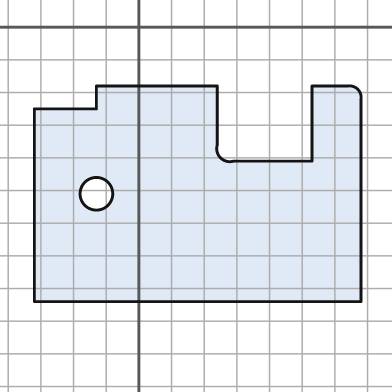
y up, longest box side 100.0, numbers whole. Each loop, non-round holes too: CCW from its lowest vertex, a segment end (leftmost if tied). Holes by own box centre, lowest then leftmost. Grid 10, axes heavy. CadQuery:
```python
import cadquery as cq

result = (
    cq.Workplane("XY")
    .moveTo(-32.0, -84.0)
    .lineTo(68.0, -84.0)
    .lineTo(68.0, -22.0)
    .threePointArc((67.0, -19.0), (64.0, -18.0))
    .lineTo(53.0, -18.0)
    .lineTo(53.0, -41.0)
    .lineTo(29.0, -41.0)
    .threePointArc((25.0, -40.0), (24.0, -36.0))
    .lineTo(24.0, -18.0)
    .lineTo(-13.0, -18.0)
    .lineTo(-13.0, -25.0)
    .lineTo(-32.0, -25.0)
    .close()
    .moveTo(-13.0, -51.0)
    .circle(5.0)
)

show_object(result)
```